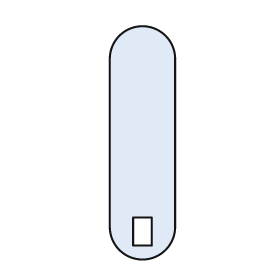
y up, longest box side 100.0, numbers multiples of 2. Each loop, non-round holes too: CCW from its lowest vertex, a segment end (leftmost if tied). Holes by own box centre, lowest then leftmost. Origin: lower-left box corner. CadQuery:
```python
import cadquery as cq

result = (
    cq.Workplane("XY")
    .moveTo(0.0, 14.0)
    .threePointArc((14.0, 0.0), (28.0, 14.0))
    .lineTo(28.0, 86.0)
    .threePointArc((14.0, 100.0), (0.0, 86.0))
    .close()
    .moveTo(10.0, 6.0)
    .lineTo(18.0, 6.0)
    .lineTo(18.0, 18.0)
    .lineTo(10.0, 18.0)
    .close()
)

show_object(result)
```